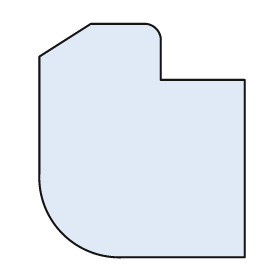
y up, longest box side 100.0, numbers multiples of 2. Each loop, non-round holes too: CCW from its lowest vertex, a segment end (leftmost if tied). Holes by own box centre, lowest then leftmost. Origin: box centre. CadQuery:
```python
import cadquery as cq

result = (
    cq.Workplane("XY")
    .moveTo(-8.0, -50.0)
    .lineTo(44.0, -50.0)
    .lineTo(44.0, 26.0)
    .lineTo(8.0, 26.0)
    .lineTo(8.0, 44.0)
    .threePointArc((6.0, 48.0), (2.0, 50.0))
    .lineTo(-22.0, 50.0)
    .lineTo(-44.0, 36.0)
    .lineTo(-44.0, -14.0)
    .threePointArc((-34.0, -40.0), (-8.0, -50.0))
    .close()
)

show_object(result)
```